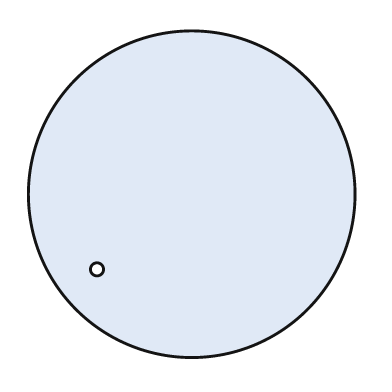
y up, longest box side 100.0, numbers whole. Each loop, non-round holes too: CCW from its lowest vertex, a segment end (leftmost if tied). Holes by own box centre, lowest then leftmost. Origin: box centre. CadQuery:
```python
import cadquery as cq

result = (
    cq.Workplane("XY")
    .moveTo(0.0, 0.0)
    .circle(50.0)
    .moveTo(-29.0, -23.0)
    .circle(2.0)
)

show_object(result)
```